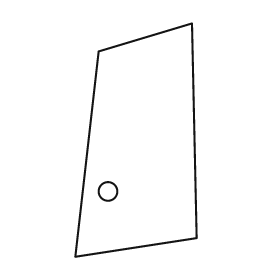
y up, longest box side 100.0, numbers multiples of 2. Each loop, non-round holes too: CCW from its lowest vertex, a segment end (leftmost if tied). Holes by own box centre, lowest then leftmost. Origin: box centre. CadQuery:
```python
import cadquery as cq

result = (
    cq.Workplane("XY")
    .moveTo(-26.0, -50.0)
    .lineTo(26.0, -42.0)
    .lineTo(24.0, 50.0)
    .lineTo(-16.0, 38.0)
    .close()
    .moveTo(-12.0, -22.0)
    .circle(4.0)
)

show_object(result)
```